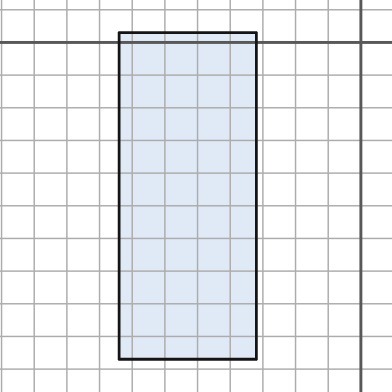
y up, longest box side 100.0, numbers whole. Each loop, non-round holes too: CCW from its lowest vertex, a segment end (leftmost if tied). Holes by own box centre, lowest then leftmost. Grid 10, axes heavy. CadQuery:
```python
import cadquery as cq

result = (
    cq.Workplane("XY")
    .moveTo(-74.0, -97.0)
    .lineTo(-32.0, -97.0)
    .lineTo(-32.0, 3.0)
    .lineTo(-74.0, 3.0)
    .close()
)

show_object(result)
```